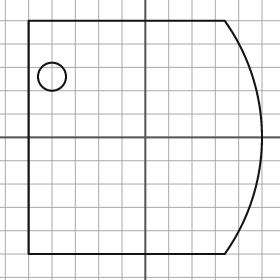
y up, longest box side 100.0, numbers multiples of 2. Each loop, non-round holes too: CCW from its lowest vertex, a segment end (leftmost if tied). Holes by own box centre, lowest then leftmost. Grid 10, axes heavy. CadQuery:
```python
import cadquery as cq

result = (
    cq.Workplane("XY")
    .moveTo(-50.0, -50.0)
    .lineTo(34.0, -50.0)
    .threePointArc((50.0, 0.0), (34.0, 50.0))
    .lineTo(-50.0, 50.0)
    .close()
    .moveTo(-40.0, 26.0)
    .circle(6.0)
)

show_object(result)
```